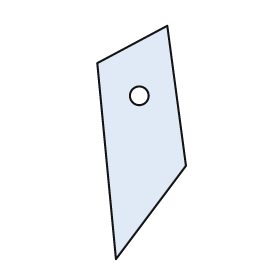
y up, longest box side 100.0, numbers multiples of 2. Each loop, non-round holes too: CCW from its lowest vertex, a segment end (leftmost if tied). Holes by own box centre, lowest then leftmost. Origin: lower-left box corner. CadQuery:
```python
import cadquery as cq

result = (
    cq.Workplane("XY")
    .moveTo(8.0, 0.0)
    .lineTo(38.0, 40.0)
    .lineTo(30.0, 100.0)
    .lineTo(0.0, 84.0)
    .close()
    .moveTo(18.0, 70.0)
    .circle(4.0)
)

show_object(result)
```